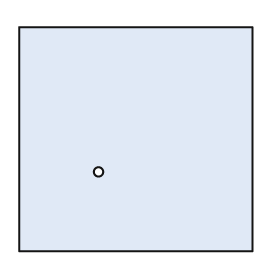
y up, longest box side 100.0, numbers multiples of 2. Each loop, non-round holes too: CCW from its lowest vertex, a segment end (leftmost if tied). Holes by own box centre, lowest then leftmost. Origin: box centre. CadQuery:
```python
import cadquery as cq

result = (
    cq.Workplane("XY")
    .moveTo(-50.0, -48.0)
    .lineTo(50.0, -48.0)
    .lineTo(50.0, 48.0)
    .lineTo(-50.0, 48.0)
    .close()
    .moveTo(-16.0, -14.0)
    .circle(2.0)
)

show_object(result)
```